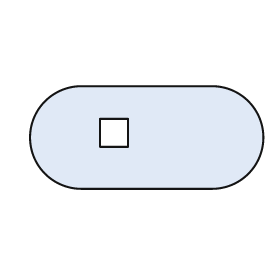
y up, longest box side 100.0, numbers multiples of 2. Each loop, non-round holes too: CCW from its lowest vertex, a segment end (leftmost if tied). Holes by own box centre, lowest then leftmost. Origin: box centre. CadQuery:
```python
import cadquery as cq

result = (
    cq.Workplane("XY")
    .moveTo(-28.0, -22.0)
    .lineTo(28.0, -22.0)
    .threePointArc((50.0, 0.0), (28.0, 22.0))
    .lineTo(-28.0, 22.0)
    .threePointArc((-50.0, 0.0), (-28.0, -22.0))
    .close()
    .moveTo(-20.0, -4.0)
    .lineTo(-8.0, -4.0)
    .lineTo(-8.0, 8.0)
    .lineTo(-20.0, 8.0)
    .close()
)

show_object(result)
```